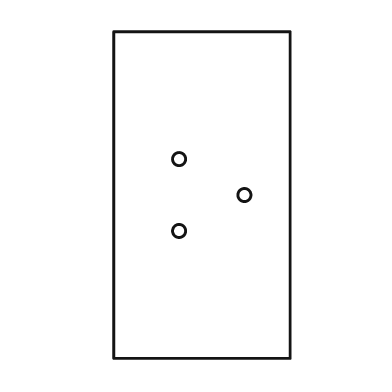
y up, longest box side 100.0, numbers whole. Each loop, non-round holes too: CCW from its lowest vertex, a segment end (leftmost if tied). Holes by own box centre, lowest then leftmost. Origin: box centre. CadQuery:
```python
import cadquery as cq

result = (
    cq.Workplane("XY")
    .moveTo(-27.0, -50.0)
    .lineTo(27.0, -50.0)
    .lineTo(27.0, 50.0)
    .lineTo(-27.0, 50.0)
    .close()
    .moveTo(-7.0, -11.0)
    .circle(2.0)
    .moveTo(13.0, 0.0)
    .circle(2.0)
    .moveTo(-7.0, 11.0)
    .circle(2.0)
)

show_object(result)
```